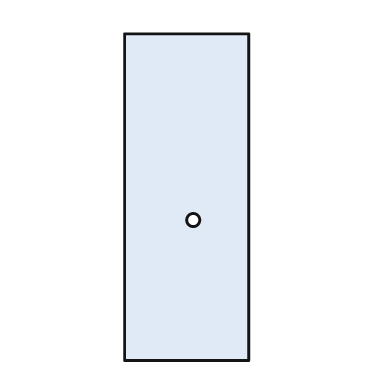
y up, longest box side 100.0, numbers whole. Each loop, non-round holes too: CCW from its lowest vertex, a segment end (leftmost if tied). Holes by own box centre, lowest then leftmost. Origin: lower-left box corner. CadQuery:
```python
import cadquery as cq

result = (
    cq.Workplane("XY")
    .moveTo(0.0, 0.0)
    .lineTo(38.0, 0.0)
    .lineTo(38.0, 100.0)
    .lineTo(0.0, 100.0)
    .close()
    .moveTo(21.0, 43.0)
    .circle(2.0)
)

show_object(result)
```